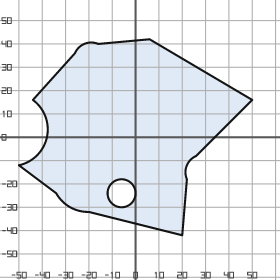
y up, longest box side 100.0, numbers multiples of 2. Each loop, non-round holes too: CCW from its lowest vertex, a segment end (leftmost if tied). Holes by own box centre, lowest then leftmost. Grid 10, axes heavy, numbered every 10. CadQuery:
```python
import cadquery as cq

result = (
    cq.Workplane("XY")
    .moveTo(20.0, -42.0)
    .lineTo(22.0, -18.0)
    .threePointArc((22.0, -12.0), (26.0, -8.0))
    .lineTo(50.0, 16.0)
    .lineTo(6.0, 42.0)
    .lineTo(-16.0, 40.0)
    .threePointArc((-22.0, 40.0), (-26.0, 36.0))
    .lineTo(-44.0, 16.0)
    .threePointArc((-38.0, 0.0), (-50.0, -12.0))
    .lineTo(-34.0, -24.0)
    .threePointArc((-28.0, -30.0), (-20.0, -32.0))
    .close()
    .moveTo(-6.0, -24.0)
    .circle(6.0)
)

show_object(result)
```